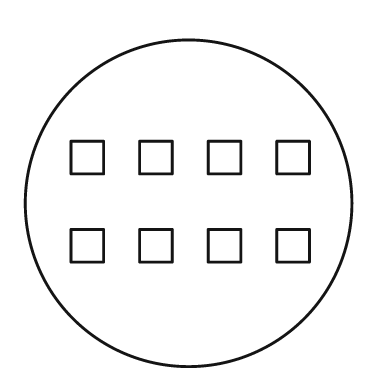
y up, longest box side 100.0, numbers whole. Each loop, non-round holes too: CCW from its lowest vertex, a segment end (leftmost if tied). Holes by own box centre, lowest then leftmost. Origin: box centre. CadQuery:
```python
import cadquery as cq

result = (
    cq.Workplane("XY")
    .moveTo(0.0, 0.0)
    .circle(50.0)
    .moveTo(-36.0, -18.0)
    .lineTo(-26.0, -18.0)
    .lineTo(-26.0, -8.0)
    .lineTo(-36.0, -8.0)
    .close()
    .moveTo(-15.0, -18.0)
    .lineTo(-5.0, -18.0)
    .lineTo(-5.0, -8.0)
    .lineTo(-15.0, -8.0)
    .close()
    .moveTo(6.0, -18.0)
    .lineTo(16.0, -18.0)
    .lineTo(16.0, -8.0)
    .lineTo(6.0, -8.0)
    .close()
    .moveTo(27.0, -18.0)
    .lineTo(37.0, -18.0)
    .lineTo(37.0, -8.0)
    .lineTo(27.0, -8.0)
    .close()
    .moveTo(-36.0, 9.0)
    .lineTo(-26.0, 9.0)
    .lineTo(-26.0, 19.0)
    .lineTo(-36.0, 19.0)
    .close()
    .moveTo(-15.0, 9.0)
    .lineTo(-5.0, 9.0)
    .lineTo(-5.0, 19.0)
    .lineTo(-15.0, 19.0)
    .close()
    .moveTo(6.0, 9.0)
    .lineTo(16.0, 9.0)
    .lineTo(16.0, 19.0)
    .lineTo(6.0, 19.0)
    .close()
    .moveTo(27.0, 9.0)
    .lineTo(37.0, 9.0)
    .lineTo(37.0, 19.0)
    .lineTo(27.0, 19.0)
    .close()
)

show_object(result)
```